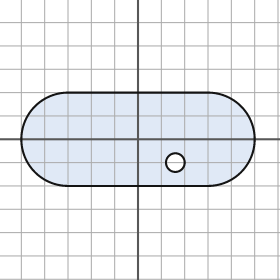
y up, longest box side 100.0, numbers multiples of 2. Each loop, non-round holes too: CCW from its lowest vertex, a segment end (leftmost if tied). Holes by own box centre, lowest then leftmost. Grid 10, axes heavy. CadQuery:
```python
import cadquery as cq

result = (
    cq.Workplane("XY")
    .moveTo(-30.0, -20.0)
    .lineTo(30.0, -20.0)
    .threePointArc((50.0, 0.0), (30.0, 20.0))
    .lineTo(-30.0, 20.0)
    .threePointArc((-50.0, 0.0), (-30.0, -20.0))
    .close()
    .moveTo(16.0, -10.0)
    .circle(4.0)
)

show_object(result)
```